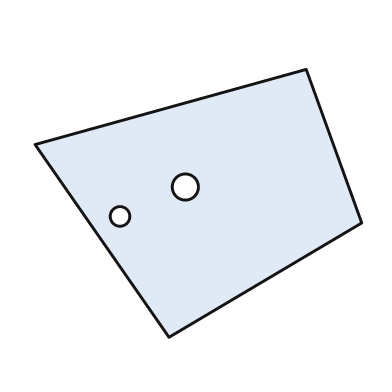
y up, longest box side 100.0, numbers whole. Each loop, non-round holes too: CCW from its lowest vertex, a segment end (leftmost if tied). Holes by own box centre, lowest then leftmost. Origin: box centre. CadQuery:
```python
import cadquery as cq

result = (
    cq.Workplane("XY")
    .moveTo(-9.0, -41.0)
    .lineTo(50.0, -6.0)
    .lineTo(33.0, 41.0)
    .lineTo(-50.0, 18.0)
    .close()
    .moveTo(-24.0, -4.0)
    .circle(3.0)
    .moveTo(-4.0, 5.0)
    .circle(4.0)
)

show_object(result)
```